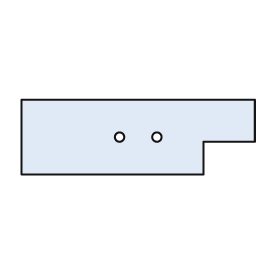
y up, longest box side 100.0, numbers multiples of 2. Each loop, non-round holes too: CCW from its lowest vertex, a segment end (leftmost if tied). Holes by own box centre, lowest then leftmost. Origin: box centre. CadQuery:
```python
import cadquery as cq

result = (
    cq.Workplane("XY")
    .moveTo(-50.0, -16.0)
    .lineTo(28.0, -16.0)
    .lineTo(28.0, -2.0)
    .lineTo(50.0, -2.0)
    .lineTo(50.0, 16.0)
    .lineTo(-50.0, 16.0)
    .close()
    .moveTo(-8.0, 0.0)
    .circle(2.0)
    .moveTo(8.0, 0.0)
    .circle(2.0)
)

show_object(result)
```